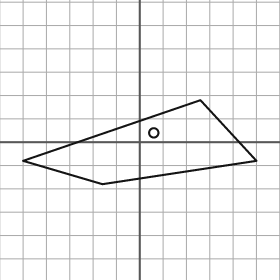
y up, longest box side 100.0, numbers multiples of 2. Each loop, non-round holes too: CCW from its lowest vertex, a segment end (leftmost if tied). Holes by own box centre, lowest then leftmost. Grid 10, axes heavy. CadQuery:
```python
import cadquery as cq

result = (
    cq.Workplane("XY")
    .moveTo(-16.0, -18.0)
    .lineTo(50.0, -8.0)
    .lineTo(26.0, 18.0)
    .lineTo(-50.0, -8.0)
    .close()
    .moveTo(6.0, 4.0)
    .circle(2.0)
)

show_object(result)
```